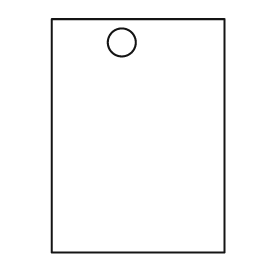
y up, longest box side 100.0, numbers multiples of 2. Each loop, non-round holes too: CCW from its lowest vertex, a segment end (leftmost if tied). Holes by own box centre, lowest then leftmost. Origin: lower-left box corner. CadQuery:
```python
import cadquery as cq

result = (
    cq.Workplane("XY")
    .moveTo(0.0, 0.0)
    .lineTo(74.0, 0.0)
    .lineTo(74.0, 100.0)
    .lineTo(0.0, 100.0)
    .close()
    .moveTo(30.0, 90.0)
    .circle(6.0)
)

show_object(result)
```